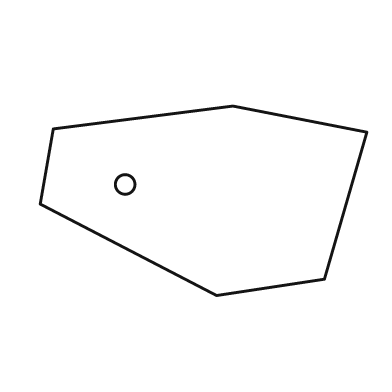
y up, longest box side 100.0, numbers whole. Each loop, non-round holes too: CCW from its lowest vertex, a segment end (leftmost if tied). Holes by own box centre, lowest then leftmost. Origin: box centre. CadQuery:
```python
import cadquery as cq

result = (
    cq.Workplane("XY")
    .moveTo(4.0, -29.0)
    .lineTo(37.0, -24.0)
    .lineTo(50.0, 21.0)
    .lineTo(9.0, 29.0)
    .lineTo(-46.0, 22.0)
    .lineTo(-50.0, -1.0)
    .close()
    .moveTo(-24.0, 5.0)
    .circle(3.0)
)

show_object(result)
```